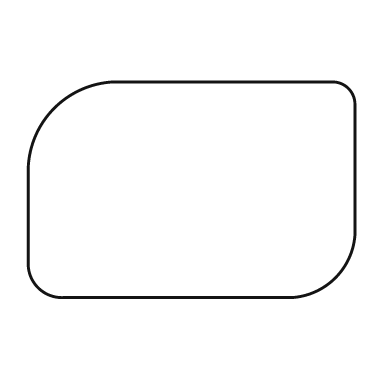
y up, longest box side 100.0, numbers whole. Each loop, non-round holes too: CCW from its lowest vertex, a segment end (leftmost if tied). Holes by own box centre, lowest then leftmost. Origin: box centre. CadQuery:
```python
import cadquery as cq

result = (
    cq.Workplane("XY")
    .moveTo(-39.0, -33.0)
    .lineTo(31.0, -33.0)
    .threePointArc((44.0, -27.0), (50.0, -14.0))
    .lineTo(50.0, 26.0)
    .threePointArc((48.0, 31.0), (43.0, 33.0))
    .lineTo(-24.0, 33.0)
    .threePointArc((-42.0, 25.0), (-50.0, 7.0))
    .lineTo(-50.0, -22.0)
    .threePointArc((-47.0, -30.0), (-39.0, -33.0))
    .close()
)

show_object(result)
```